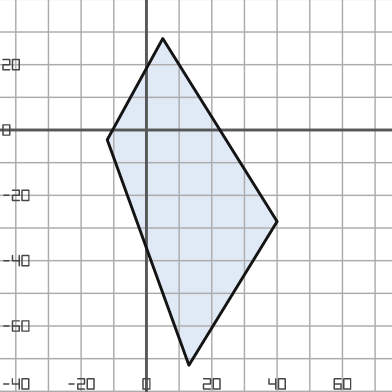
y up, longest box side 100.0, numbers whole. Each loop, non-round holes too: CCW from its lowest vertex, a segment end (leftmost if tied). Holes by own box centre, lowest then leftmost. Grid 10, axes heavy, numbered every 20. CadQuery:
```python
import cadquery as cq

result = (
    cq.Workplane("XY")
    .moveTo(13.0, -72.0)
    .lineTo(40.0, -28.0)
    .lineTo(5.0, 28.0)
    .lineTo(-12.0, -3.0)
    .close()
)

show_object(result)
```